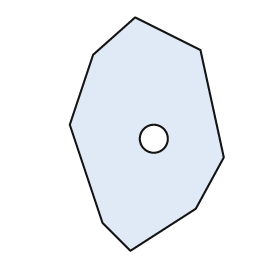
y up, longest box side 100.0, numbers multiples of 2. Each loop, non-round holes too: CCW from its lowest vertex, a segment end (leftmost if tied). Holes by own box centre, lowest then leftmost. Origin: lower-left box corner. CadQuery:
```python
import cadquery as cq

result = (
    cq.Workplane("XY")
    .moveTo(26.0, 0.0)
    .lineTo(54.0, 18.0)
    .lineTo(66.0, 40.0)
    .lineTo(56.0, 86.0)
    .lineTo(28.0, 100.0)
    .lineTo(10.0, 84.0)
    .lineTo(0.0, 54.0)
    .lineTo(14.0, 12.0)
    .close()
    .moveTo(36.0, 48.0)
    .circle(6.0)
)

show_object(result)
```